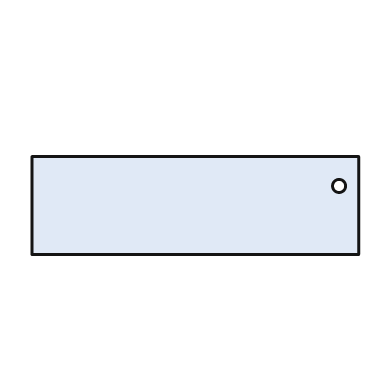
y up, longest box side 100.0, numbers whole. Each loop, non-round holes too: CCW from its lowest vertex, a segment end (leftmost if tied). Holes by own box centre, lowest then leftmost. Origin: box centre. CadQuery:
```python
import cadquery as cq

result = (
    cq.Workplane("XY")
    .moveTo(-50.0, -15.0)
    .lineTo(50.0, -15.0)
    .lineTo(50.0, 15.0)
    .lineTo(-50.0, 15.0)
    .close()
    .moveTo(44.0, 6.0)
    .circle(2.0)
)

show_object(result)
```